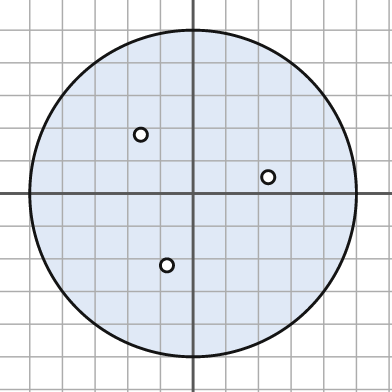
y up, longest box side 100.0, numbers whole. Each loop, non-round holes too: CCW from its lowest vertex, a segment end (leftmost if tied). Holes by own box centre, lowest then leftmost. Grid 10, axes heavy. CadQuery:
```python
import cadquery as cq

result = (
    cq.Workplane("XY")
    .moveTo(0.0, 0.0)
    .circle(50.0)
    .moveTo(-8.0, -22.0)
    .circle(2.0)
    .moveTo(23.0, 5.0)
    .circle(2.0)
    .moveTo(-16.0, 18.0)
    .circle(2.0)
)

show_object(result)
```